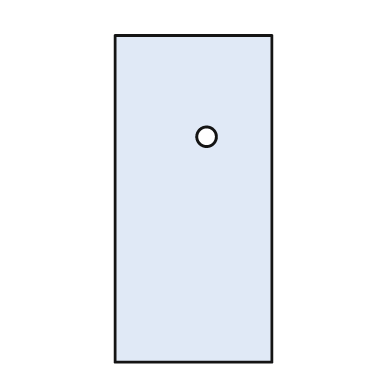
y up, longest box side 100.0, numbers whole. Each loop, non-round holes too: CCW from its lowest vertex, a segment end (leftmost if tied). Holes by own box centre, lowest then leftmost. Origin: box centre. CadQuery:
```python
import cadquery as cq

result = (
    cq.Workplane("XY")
    .moveTo(-24.0, -50.0)
    .lineTo(24.0, -50.0)
    .lineTo(24.0, 50.0)
    .lineTo(-24.0, 50.0)
    .close()
    .moveTo(4.0, 19.0)
    .circle(3.0)
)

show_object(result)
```